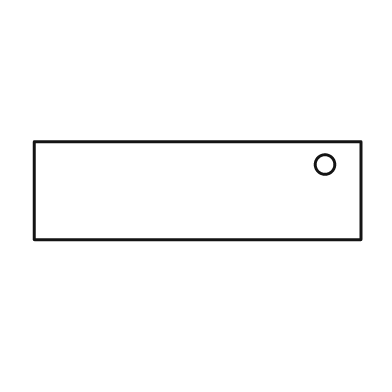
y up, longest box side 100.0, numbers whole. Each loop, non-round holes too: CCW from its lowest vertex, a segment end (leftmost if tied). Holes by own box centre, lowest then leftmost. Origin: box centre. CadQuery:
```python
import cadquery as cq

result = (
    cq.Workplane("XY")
    .moveTo(-50.0, -15.0)
    .lineTo(50.0, -15.0)
    .lineTo(50.0, 15.0)
    .lineTo(-50.0, 15.0)
    .close()
    .moveTo(39.0, 8.0)
    .circle(3.0)
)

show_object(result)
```